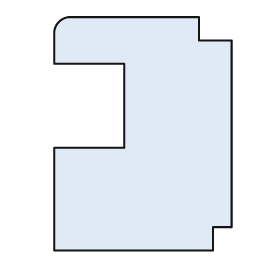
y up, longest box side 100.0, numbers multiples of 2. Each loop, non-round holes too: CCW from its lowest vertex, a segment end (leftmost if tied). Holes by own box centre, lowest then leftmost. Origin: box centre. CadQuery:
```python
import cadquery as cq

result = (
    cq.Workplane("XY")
    .moveTo(-38.0, -50.0)
    .lineTo(30.0, -50.0)
    .lineTo(30.0, -40.0)
    .lineTo(38.0, -40.0)
    .lineTo(38.0, 40.0)
    .lineTo(24.0, 40.0)
    .lineTo(24.0, 50.0)
    .lineTo(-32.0, 50.0)
    .threePointArc((-36.0, 48.0), (-38.0, 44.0))
    .lineTo(-38.0, 30.0)
    .lineTo(-8.0, 30.0)
    .lineTo(-8.0, -6.0)
    .lineTo(-38.0, -6.0)
    .close()
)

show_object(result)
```